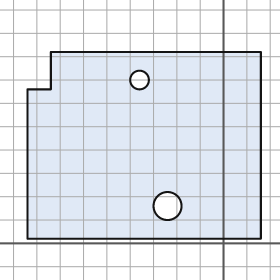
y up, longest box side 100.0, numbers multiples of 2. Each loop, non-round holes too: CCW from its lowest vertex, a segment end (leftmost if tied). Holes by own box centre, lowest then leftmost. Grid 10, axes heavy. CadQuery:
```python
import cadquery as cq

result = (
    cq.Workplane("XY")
    .moveTo(-84.0, 2.0)
    .lineTo(16.0, 2.0)
    .lineTo(16.0, 82.0)
    .lineTo(-74.0, 82.0)
    .lineTo(-74.0, 66.0)
    .lineTo(-84.0, 66.0)
    .close()
    .moveTo(-24.0, 16.0)
    .circle(6.0)
    .moveTo(-36.0, 70.0)
    .circle(4.0)
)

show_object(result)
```